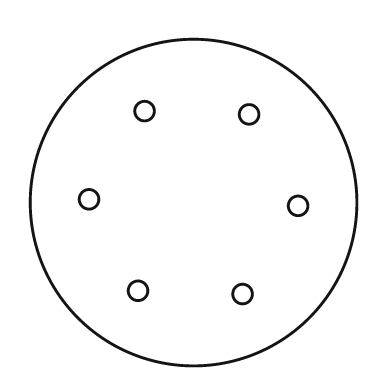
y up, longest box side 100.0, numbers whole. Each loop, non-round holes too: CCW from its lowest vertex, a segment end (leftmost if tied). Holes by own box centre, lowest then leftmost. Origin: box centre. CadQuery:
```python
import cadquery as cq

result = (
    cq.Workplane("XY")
    .moveTo(0.0, 0.0)
    .circle(50.0)
    .moveTo(15.0, -28.0)
    .circle(3.0)
    .moveTo(-17.0, -27.0)
    .circle(3.0)
    .moveTo(32.0, -1.0)
    .circle(3.0)
    .moveTo(-32.0, 1.0)
    .circle(3.0)
    .moveTo(17.0, 27.0)
    .circle(3.0)
    .moveTo(-15.0, 28.0)
    .circle(3.0)
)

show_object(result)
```